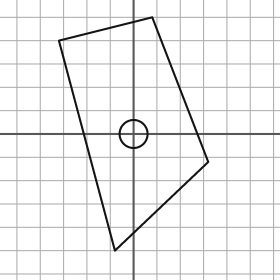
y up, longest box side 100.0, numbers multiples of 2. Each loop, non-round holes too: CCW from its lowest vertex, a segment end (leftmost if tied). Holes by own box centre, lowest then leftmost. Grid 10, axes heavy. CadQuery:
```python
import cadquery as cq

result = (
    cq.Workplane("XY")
    .moveTo(-8.0, -50.0)
    .lineTo(32.0, -12.0)
    .lineTo(8.0, 50.0)
    .lineTo(-32.0, 40.0)
    .close()
    .moveTo(0.0, 0.0)
    .circle(6.0)
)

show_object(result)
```